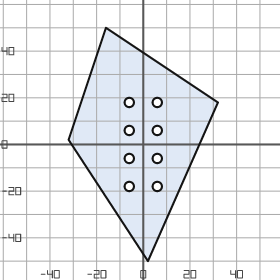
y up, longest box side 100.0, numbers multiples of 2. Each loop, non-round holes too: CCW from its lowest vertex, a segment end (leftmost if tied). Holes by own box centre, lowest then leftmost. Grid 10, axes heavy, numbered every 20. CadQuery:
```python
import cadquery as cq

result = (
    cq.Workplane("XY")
    .moveTo(2.0, -50.0)
    .lineTo(32.0, 18.0)
    .lineTo(-16.0, 50.0)
    .lineTo(-32.0, 2.0)
    .close()
    .moveTo(-6.0, -18.0)
    .circle(2.0)
    .moveTo(6.0, -18.0)
    .circle(2.0)
    .moveTo(-6.0, -6.0)
    .circle(2.0)
    .moveTo(6.0, -6.0)
    .circle(2.0)
    .moveTo(-6.0, 6.0)
    .circle(2.0)
    .moveTo(6.0, 6.0)
    .circle(2.0)
    .moveTo(-6.0, 18.0)
    .circle(2.0)
    .moveTo(6.0, 18.0)
    .circle(2.0)
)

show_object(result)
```